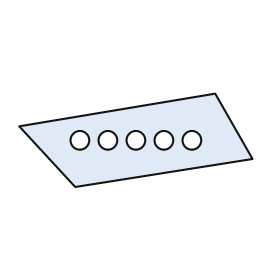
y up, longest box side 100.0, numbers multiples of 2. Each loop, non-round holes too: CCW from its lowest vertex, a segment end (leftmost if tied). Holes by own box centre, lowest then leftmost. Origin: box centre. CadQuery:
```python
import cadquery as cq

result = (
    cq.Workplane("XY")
    .moveTo(-26.0, -20.0)
    .lineTo(50.0, -8.0)
    .lineTo(34.0, 20.0)
    .lineTo(-50.0, 6.0)
    .close()
    .moveTo(-24.0, 0.0)
    .circle(4.0)
    .moveTo(-12.0, 0.0)
    .circle(4.0)
    .moveTo(0.0, 0.0)
    .circle(4.0)
    .moveTo(12.0, 0.0)
    .circle(4.0)
    .moveTo(24.0, 0.0)
    .circle(4.0)
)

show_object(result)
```